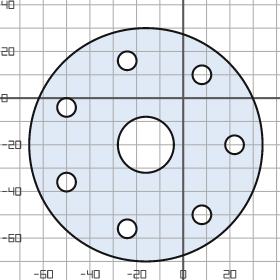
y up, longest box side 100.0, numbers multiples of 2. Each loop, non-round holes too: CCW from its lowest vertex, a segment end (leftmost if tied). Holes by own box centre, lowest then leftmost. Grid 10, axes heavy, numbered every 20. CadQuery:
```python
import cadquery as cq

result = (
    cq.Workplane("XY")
    .moveTo(-16.0, -20.0)
    .circle(50.0)
    .moveTo(-24.0, -56.0)
    .circle(4.0)
    .moveTo(8.0, -50.0)
    .circle(4.0)
    .moveTo(-50.0, -36.0)
    .circle(4.0)
    .moveTo(-16.0, -20.0)
    .circle(12.0)
    .moveTo(22.0, -20.0)
    .circle(4.0)
    .moveTo(-50.0, -4.0)
    .circle(4.0)
    .moveTo(8.0, 10.0)
    .circle(4.0)
    .moveTo(-24.0, 16.0)
    .circle(4.0)
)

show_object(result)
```